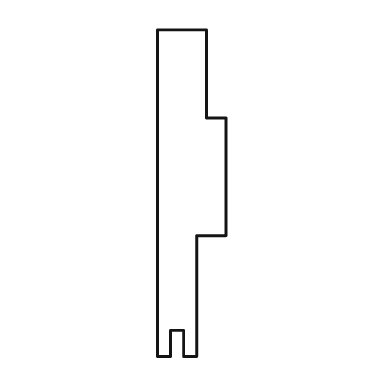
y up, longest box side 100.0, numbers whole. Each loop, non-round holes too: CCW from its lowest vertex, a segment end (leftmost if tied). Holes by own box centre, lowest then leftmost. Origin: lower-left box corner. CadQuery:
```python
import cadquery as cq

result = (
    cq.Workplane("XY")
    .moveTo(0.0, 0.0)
    .lineTo(4.0, 0.0)
    .lineTo(4.0, 8.0)
    .lineTo(8.0, 8.0)
    .lineTo(8.0, 0.0)
    .lineTo(12.0, 0.0)
    .lineTo(12.0, 37.0)
    .lineTo(21.0, 37.0)
    .lineTo(21.0, 73.0)
    .lineTo(15.0, 73.0)
    .lineTo(15.0, 100.0)
    .lineTo(0.0, 100.0)
    .close()
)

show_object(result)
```